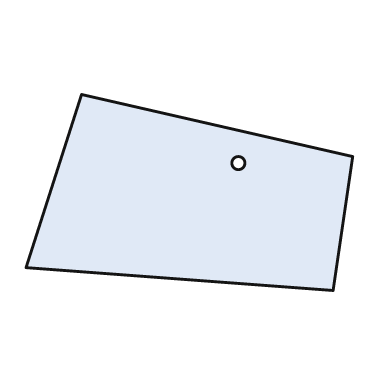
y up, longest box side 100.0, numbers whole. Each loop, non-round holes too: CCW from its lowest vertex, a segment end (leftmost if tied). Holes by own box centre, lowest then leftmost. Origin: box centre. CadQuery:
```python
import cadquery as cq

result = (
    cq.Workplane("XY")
    .moveTo(44.0, -30.0)
    .lineTo(50.0, 11.0)
    .lineTo(-33.0, 30.0)
    .lineTo(-50.0, -23.0)
    .close()
    .moveTo(15.0, 9.0)
    .circle(2.0)
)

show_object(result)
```